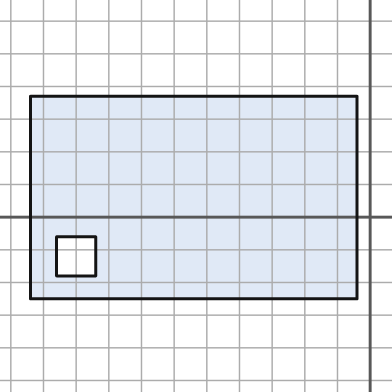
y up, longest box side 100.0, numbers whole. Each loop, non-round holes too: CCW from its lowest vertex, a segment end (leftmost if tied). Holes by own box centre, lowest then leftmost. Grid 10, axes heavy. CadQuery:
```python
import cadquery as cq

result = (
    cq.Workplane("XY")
    .moveTo(-104.0, -25.0)
    .lineTo(-4.0, -25.0)
    .lineTo(-4.0, 37.0)
    .lineTo(-104.0, 37.0)
    .close()
    .moveTo(-96.0, -18.0)
    .lineTo(-84.0, -18.0)
    .lineTo(-84.0, -6.0)
    .lineTo(-96.0, -6.0)
    .close()
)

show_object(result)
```